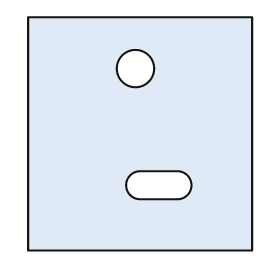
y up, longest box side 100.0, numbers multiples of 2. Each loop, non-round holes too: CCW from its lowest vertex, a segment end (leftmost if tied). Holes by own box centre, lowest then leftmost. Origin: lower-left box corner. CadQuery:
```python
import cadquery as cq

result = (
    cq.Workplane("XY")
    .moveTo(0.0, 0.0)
    .lineTo(96.0, 0.0)
    .lineTo(96.0, 100.0)
    .lineTo(0.0, 100.0)
    .close()
    .moveTo(48.0, 22.0)
    .lineTo(64.0, 22.0)
    .threePointArc((70.0, 28.0), (64.0, 34.0))
    .lineTo(48.0, 34.0)
    .threePointArc((42.0, 28.0), (48.0, 22.0))
    .close()
    .moveTo(46.0, 78.0)
    .circle(8.0)
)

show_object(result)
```